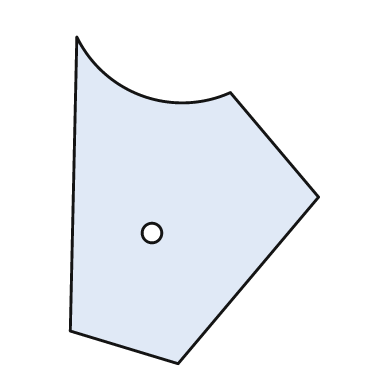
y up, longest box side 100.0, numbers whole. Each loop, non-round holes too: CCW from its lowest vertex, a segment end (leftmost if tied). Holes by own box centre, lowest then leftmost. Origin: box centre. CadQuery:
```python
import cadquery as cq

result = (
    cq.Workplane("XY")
    .moveTo(-5.0, -50.0)
    .lineTo(38.0, 1.0)
    .lineTo(11.0, 33.0)
    .threePointArc((-16.0, 32.0), (-36.0, 50.0))
    .lineTo(-38.0, -40.0)
    .close()
    .moveTo(-13.0, -10.0)
    .circle(3.0)
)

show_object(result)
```